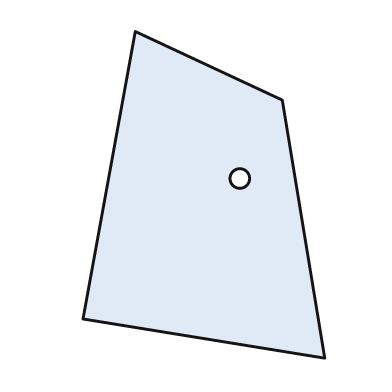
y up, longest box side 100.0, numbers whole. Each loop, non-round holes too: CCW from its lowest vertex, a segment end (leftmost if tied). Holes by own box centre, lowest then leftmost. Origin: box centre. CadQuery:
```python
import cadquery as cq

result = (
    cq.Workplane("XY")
    .moveTo(37.0, -50.0)
    .lineTo(24.0, 29.0)
    .lineTo(-21.0, 50.0)
    .lineTo(-37.0, -38.0)
    .close()
    .moveTo(11.0, 5.0)
    .circle(3.0)
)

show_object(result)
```